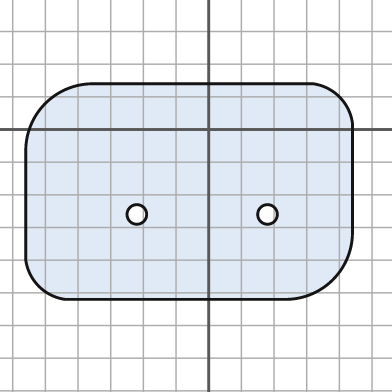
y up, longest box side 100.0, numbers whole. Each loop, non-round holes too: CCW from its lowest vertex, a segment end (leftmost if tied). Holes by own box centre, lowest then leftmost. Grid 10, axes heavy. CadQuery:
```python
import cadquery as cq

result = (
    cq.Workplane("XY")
    .moveTo(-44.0, -52.0)
    .lineTo(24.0, -52.0)
    .threePointArc((38.0, -46.0), (44.0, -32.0))
    .lineTo(44.0, 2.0)
    .threePointArc((40.0, 10.0), (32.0, 14.0))
    .lineTo(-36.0, 14.0)
    .threePointArc((-50.0, 8.0), (-56.0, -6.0))
    .lineTo(-56.0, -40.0)
    .threePointArc((-52.0, -48.0), (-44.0, -52.0))
    .close()
    .moveTo(-22.0, -26.0)
    .circle(3.0)
    .moveTo(18.0, -26.0)
    .circle(3.0)
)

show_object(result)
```